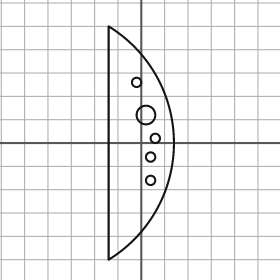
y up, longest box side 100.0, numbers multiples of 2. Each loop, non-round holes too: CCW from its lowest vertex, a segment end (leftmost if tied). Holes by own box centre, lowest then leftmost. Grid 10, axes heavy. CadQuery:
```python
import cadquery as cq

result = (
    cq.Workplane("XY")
    .moveTo(-14.0, -50.0)
    .threePointArc((14.0, 0.0), (-14.0, 50.0))
    .close()
    .moveTo(4.0, -16.0)
    .circle(2.0)
    .moveTo(4.0, -6.0)
    .circle(2.0)
    .moveTo(6.0, 2.0)
    .circle(2.0)
    .moveTo(2.0, 12.0)
    .circle(4.0)
    .moveTo(-2.0, 26.0)
    .circle(2.0)
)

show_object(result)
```